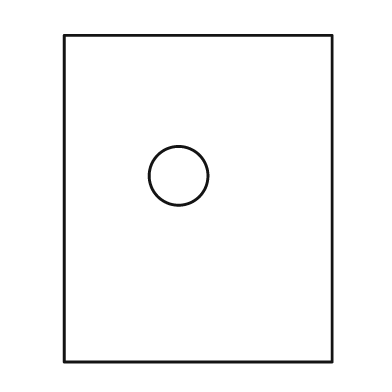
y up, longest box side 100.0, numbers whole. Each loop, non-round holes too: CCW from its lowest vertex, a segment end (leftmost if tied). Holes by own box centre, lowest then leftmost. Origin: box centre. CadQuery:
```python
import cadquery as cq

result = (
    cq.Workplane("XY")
    .moveTo(-41.0, -50.0)
    .lineTo(41.0, -50.0)
    .lineTo(41.0, 50.0)
    .lineTo(-41.0, 50.0)
    .close()
    .moveTo(-6.0, 7.0)
    .circle(9.0)
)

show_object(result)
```